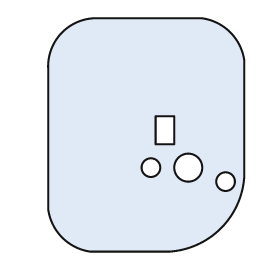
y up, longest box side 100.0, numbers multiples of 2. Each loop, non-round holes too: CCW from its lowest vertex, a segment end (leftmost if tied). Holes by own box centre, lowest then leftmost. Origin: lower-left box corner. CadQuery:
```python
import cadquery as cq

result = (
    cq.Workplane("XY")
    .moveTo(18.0, 0.0)
    .lineTo(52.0, 0.0)
    .threePointArc((74.0, 10.0), (84.0, 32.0))
    .lineTo(84.0, 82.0)
    .threePointArc((78.0, 94.0), (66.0, 100.0))
    .lineTo(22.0, 100.0)
    .threePointArc((6.0, 94.0), (0.0, 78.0))
    .lineTo(0.0, 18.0)
    .threePointArc((6.0, 6.0), (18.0, 0.0))
    .close()
    .moveTo(76.0, 30.0)
    .circle(4.0)
    .moveTo(44.0, 36.0)
    .circle(4.0)
    .moveTo(60.0, 36.0)
    .circle(6.0)
    .moveTo(46.0, 46.0)
    .lineTo(54.0, 46.0)
    .lineTo(54.0, 58.0)
    .lineTo(46.0, 58.0)
    .close()
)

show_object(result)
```